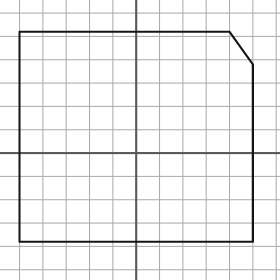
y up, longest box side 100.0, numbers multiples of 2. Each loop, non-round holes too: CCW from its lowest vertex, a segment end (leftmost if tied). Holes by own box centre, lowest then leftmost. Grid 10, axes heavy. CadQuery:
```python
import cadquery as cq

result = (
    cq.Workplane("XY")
    .moveTo(-50.0, -38.0)
    .lineTo(50.0, -38.0)
    .lineTo(50.0, 38.0)
    .lineTo(40.0, 52.0)
    .lineTo(-50.0, 52.0)
    .close()
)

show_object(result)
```